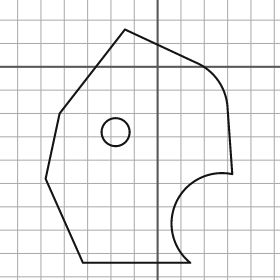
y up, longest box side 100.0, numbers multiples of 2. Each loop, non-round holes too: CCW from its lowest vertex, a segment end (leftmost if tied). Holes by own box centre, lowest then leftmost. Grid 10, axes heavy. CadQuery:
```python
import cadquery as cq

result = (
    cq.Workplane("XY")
    .moveTo(-32.0, -84.0)
    .lineTo(14.0, -84.0)
    .threePointArc((8.0, -58.0), (32.0, -46.0))
    .lineTo(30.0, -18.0)
    .threePointArc((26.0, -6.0), (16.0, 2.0))
    .lineTo(-14.0, 16.0)
    .lineTo(-42.0, -20.0)
    .lineTo(-48.0, -48.0)
    .close()
    .moveTo(-18.0, -28.0)
    .circle(6.0)
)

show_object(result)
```